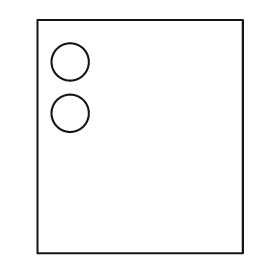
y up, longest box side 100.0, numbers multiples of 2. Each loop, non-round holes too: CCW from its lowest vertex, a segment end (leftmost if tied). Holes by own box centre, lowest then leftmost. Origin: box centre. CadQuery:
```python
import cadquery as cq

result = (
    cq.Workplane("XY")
    .moveTo(-44.0, -50.0)
    .lineTo(44.0, -50.0)
    .lineTo(44.0, 50.0)
    .lineTo(-44.0, 50.0)
    .close()
    .moveTo(-30.0, 10.0)
    .circle(8.0)
    .moveTo(-30.0, 32.0)
    .circle(8.0)
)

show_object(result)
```